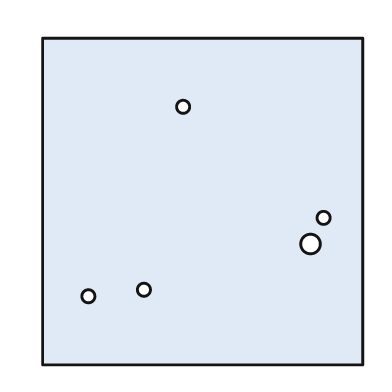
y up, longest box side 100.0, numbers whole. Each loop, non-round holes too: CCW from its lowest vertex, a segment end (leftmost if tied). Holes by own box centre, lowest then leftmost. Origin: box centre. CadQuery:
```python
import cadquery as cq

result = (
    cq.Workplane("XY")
    .moveTo(-49.0, -50.0)
    .lineTo(49.0, -50.0)
    .lineTo(49.0, 50.0)
    .lineTo(-49.0, 50.0)
    .close()
    .moveTo(-35.0, -29.0)
    .circle(2.0)
    .moveTo(-18.0, -27.0)
    .circle(2.0)
    .moveTo(33.0, -13.0)
    .circle(3.0)
    .moveTo(37.0, -5.0)
    .circle(2.0)
    .moveTo(-6.0, 29.0)
    .circle(2.0)
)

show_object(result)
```